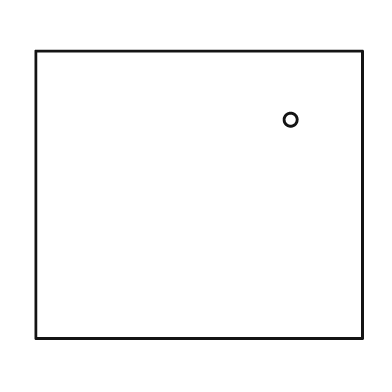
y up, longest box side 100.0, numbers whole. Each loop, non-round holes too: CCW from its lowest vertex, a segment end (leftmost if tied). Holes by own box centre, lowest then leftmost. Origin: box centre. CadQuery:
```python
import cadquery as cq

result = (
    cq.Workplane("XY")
    .moveTo(-50.0, -44.0)
    .lineTo(50.0, -44.0)
    .lineTo(50.0, 44.0)
    .lineTo(-50.0, 44.0)
    .close()
    .moveTo(28.0, 23.0)
    .circle(2.0)
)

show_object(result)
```